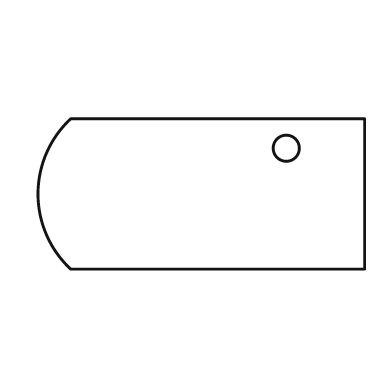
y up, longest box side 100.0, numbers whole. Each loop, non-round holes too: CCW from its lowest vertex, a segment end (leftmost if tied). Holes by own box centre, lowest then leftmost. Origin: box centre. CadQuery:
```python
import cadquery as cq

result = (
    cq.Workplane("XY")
    .moveTo(-40.0, -23.0)
    .lineTo(50.0, -23.0)
    .lineTo(50.0, 23.0)
    .lineTo(-40.0, 23.0)
    .threePointArc((-50.0, 0.0), (-40.0, -23.0))
    .close()
    .moveTo(26.0, 14.0)
    .circle(4.0)
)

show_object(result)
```